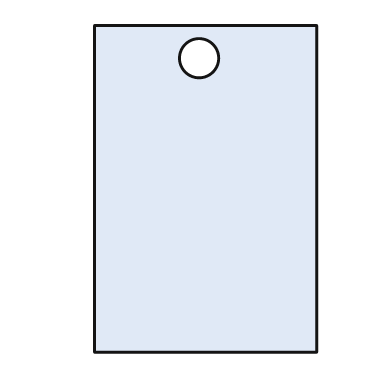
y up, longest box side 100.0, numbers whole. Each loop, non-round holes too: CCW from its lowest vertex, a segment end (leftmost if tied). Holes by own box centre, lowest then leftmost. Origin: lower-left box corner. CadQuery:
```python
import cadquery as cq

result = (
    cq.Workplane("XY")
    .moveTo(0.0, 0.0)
    .lineTo(68.0, 0.0)
    .lineTo(68.0, 100.0)
    .lineTo(0.0, 100.0)
    .close()
    .moveTo(32.0, 90.0)
    .circle(6.0)
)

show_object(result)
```